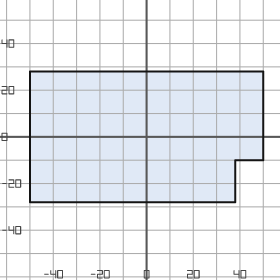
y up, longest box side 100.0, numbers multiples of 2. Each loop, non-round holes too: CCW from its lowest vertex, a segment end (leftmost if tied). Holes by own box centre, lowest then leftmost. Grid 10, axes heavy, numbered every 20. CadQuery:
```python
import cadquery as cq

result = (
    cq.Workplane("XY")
    .moveTo(-50.0, -28.0)
    .lineTo(38.0, -28.0)
    .lineTo(38.0, -10.0)
    .lineTo(50.0, -10.0)
    .lineTo(50.0, 28.0)
    .lineTo(-50.0, 28.0)
    .close()
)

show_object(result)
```